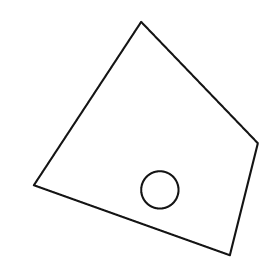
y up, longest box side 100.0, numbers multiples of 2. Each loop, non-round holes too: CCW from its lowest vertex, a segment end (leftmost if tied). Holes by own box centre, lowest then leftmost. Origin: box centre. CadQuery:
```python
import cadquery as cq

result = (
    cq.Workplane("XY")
    .moveTo(36.0, -50.0)
    .lineTo(48.0, -2.0)
    .lineTo(-2.0, 50.0)
    .lineTo(-48.0, -20.0)
    .close()
    .moveTo(6.0, -22.0)
    .circle(8.0)
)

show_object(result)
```